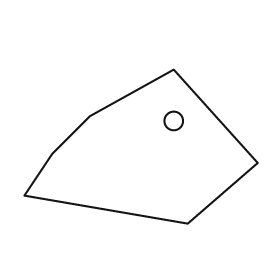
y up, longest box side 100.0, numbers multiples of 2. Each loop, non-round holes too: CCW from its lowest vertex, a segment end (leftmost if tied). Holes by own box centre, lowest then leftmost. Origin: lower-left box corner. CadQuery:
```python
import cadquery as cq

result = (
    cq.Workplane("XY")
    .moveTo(70.0, 0.0)
    .lineTo(100.0, 26.0)
    .lineTo(64.0, 66.0)
    .lineTo(28.0, 46.0)
    .lineTo(12.0, 30.0)
    .lineTo(0.0, 12.0)
    .close()
    .moveTo(64.0, 44.0)
    .circle(4.0)
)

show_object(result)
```